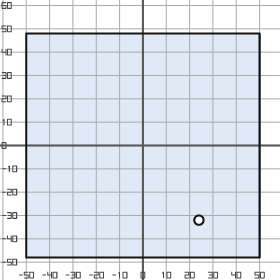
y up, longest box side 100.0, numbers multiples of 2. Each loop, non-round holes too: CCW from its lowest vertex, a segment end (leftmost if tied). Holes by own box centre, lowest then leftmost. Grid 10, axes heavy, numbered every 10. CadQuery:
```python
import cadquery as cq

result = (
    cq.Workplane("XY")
    .moveTo(-50.0, -48.0)
    .lineTo(50.0, -48.0)
    .lineTo(50.0, 48.0)
    .lineTo(-50.0, 48.0)
    .close()
    .moveTo(24.0, -32.0)
    .circle(2.0)
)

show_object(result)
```